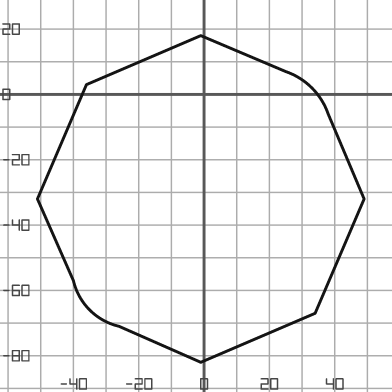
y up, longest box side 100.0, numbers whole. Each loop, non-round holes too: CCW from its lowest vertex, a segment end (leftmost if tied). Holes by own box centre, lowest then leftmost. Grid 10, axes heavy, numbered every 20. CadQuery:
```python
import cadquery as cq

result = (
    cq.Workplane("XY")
    .moveTo(-1.0, -82.0)
    .lineTo(34.0, -67.0)
    .lineTo(49.0, -32.0)
    .lineTo(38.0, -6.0)
    .threePointArc((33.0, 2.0), (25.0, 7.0))
    .lineTo(-1.0, 18.0)
    .lineTo(-36.0, 3.0)
    .lineTo(-51.0, -32.0)
    .lineTo(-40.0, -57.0)
    .threePointArc((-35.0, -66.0), (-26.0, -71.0))
    .close()
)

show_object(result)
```